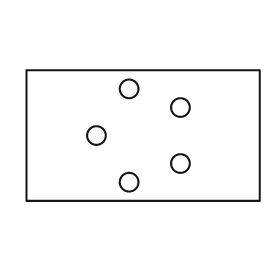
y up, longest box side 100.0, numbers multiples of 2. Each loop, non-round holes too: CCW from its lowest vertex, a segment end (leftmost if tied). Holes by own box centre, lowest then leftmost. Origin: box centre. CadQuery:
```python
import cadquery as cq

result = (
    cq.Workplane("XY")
    .moveTo(-50.0, -28.0)
    .lineTo(50.0, -28.0)
    .lineTo(50.0, 28.0)
    .lineTo(-50.0, 28.0)
    .close()
    .moveTo(-6.0, -20.0)
    .circle(4.0)
    .moveTo(16.0, -12.0)
    .circle(4.0)
    .moveTo(-20.0, 0.0)
    .circle(4.0)
    .moveTo(16.0, 12.0)
    .circle(4.0)
    .moveTo(-6.0, 20.0)
    .circle(4.0)
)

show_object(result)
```